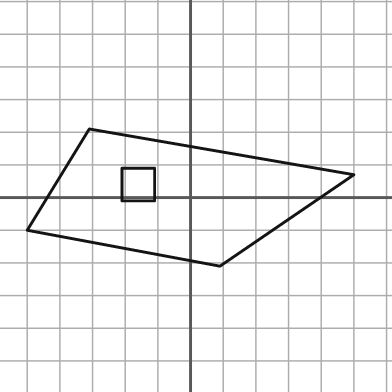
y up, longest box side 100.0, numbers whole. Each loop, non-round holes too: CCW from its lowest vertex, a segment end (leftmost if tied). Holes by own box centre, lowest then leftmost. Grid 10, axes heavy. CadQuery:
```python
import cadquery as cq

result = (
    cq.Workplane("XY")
    .moveTo(9.0, -21.0)
    .lineTo(50.0, 7.0)
    .lineTo(-31.0, 21.0)
    .lineTo(-50.0, -10.0)
    .close()
    .moveTo(-21.0, -1.0)
    .lineTo(-11.0, -1.0)
    .lineTo(-11.0, 9.0)
    .lineTo(-21.0, 9.0)
    .close()
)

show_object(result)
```